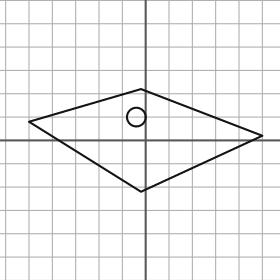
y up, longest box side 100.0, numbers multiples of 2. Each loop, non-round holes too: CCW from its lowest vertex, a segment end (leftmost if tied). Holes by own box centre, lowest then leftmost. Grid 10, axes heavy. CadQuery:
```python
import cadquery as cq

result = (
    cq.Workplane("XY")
    .moveTo(-2.0, -22.0)
    .lineTo(50.0, 2.0)
    .lineTo(-2.0, 22.0)
    .lineTo(-50.0, 8.0)
    .close()
    .moveTo(-4.0, 10.0)
    .circle(4.0)
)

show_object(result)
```